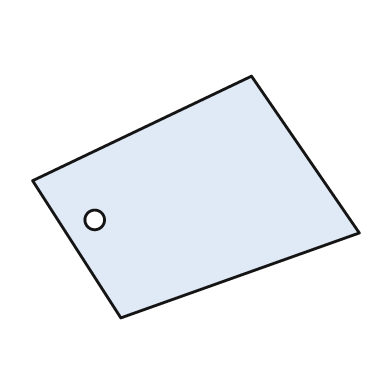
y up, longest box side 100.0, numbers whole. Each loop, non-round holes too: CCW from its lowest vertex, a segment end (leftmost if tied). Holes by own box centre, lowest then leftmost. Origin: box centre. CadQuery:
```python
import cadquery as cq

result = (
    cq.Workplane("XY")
    .moveTo(-23.0, -37.0)
    .lineTo(50.0, -11.0)
    .lineTo(17.0, 37.0)
    .lineTo(-50.0, 5.0)
    .close()
    .moveTo(-31.0, -7.0)
    .circle(3.0)
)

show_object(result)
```